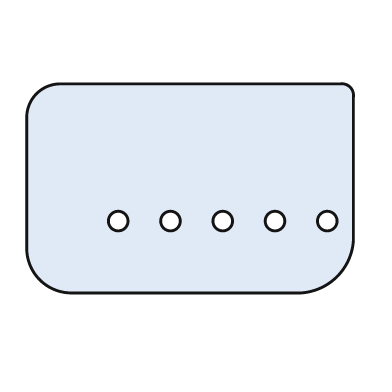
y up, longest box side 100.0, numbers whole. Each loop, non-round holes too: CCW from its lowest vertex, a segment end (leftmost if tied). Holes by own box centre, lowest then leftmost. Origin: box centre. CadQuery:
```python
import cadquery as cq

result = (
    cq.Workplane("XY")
    .moveTo(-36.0, -32.0)
    .lineTo(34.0, -32.0)
    .threePointArc((45.0, -27.0), (50.0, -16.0))
    .lineTo(50.0, 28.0)
    .threePointArc((49.0, 31.0), (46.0, 32.0))
    .lineTo(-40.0, 32.0)
    .threePointArc((-47.0, 29.0), (-50.0, 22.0))
    .lineTo(-50.0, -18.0)
    .threePointArc((-46.0, -28.0), (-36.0, -32.0))
    .close()
    .moveTo(-22.0, -10.0)
    .circle(3.0)
    .moveTo(-6.0, -10.0)
    .circle(3.0)
    .moveTo(10.0, -10.0)
    .circle(3.0)
    .moveTo(26.0, -10.0)
    .circle(3.0)
    .moveTo(42.0, -10.0)
    .circle(3.0)
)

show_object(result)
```